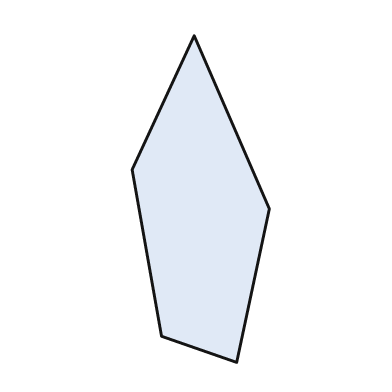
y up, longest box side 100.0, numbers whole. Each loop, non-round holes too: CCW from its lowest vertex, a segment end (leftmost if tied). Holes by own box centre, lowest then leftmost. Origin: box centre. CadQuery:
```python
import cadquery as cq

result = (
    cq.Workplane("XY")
    .moveTo(11.0, -50.0)
    .lineTo(21.0, -3.0)
    .lineTo(-2.0, 50.0)
    .lineTo(-21.0, 9.0)
    .lineTo(-12.0, -42.0)
    .close()
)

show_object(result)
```